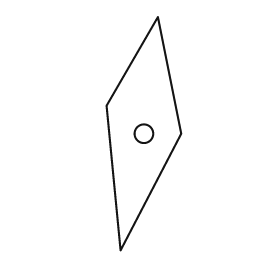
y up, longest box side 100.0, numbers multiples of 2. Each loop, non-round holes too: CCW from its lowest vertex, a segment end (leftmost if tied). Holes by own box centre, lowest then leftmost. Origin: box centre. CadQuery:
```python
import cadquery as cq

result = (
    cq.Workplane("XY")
    .moveTo(-10.0, -50.0)
    .lineTo(16.0, 0.0)
    .lineTo(6.0, 50.0)
    .lineTo(-16.0, 12.0)
    .close()
    .moveTo(0.0, 0.0)
    .circle(4.0)
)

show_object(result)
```